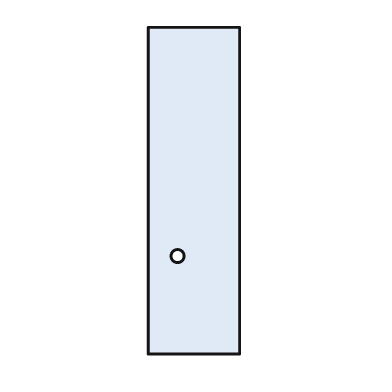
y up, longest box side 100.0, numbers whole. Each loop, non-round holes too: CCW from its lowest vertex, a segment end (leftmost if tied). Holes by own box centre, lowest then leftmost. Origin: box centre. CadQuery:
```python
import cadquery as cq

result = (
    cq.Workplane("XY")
    .moveTo(-14.0, -50.0)
    .lineTo(14.0, -50.0)
    .lineTo(14.0, 50.0)
    .lineTo(-14.0, 50.0)
    .close()
    .moveTo(-5.0, -20.0)
    .circle(2.0)
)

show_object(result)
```